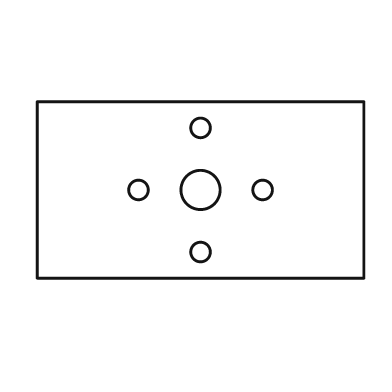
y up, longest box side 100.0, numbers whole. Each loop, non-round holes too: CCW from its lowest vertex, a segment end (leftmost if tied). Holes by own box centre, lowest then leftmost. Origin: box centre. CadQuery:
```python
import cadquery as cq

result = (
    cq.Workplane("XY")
    .moveTo(-50.0, -27.0)
    .lineTo(50.0, -27.0)
    .lineTo(50.0, 27.0)
    .lineTo(-50.0, 27.0)
    .close()
    .moveTo(0.0, -19.0)
    .circle(3.0)
    .moveTo(-19.0, 0.0)
    .circle(3.0)
    .moveTo(0.0, 0.0)
    .circle(6.0)
    .moveTo(19.0, 0.0)
    .circle(3.0)
    .moveTo(0.0, 19.0)
    .circle(3.0)
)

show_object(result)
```